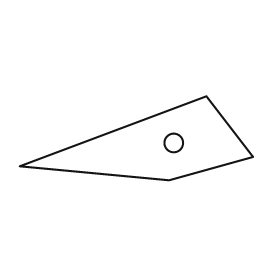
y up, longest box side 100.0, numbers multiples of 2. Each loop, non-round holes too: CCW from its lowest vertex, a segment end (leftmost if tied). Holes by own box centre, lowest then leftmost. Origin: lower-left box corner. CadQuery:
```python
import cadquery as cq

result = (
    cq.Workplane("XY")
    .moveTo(64.0, 0.0)
    .lineTo(100.0, 10.0)
    .lineTo(80.0, 36.0)
    .lineTo(0.0, 6.0)
    .close()
    .moveTo(66.0, 16.0)
    .circle(4.0)
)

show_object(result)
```